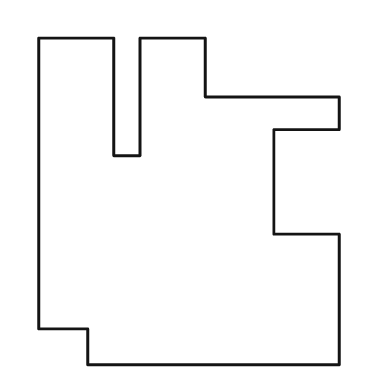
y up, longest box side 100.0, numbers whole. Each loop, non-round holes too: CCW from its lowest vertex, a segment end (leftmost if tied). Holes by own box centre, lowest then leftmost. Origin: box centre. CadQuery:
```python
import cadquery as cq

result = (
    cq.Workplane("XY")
    .moveTo(-31.0, -50.0)
    .lineTo(46.0, -50.0)
    .lineTo(46.0, -10.0)
    .lineTo(26.0, -10.0)
    .lineTo(26.0, 22.0)
    .lineTo(46.0, 22.0)
    .lineTo(46.0, 32.0)
    .lineTo(5.0, 32.0)
    .lineTo(5.0, 50.0)
    .lineTo(-15.0, 50.0)
    .lineTo(-15.0, 14.0)
    .lineTo(-23.0, 14.0)
    .lineTo(-23.0, 50.0)
    .lineTo(-46.0, 50.0)
    .lineTo(-46.0, -39.0)
    .lineTo(-31.0, -39.0)
    .close()
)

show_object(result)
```